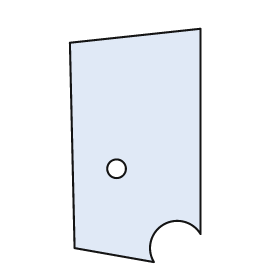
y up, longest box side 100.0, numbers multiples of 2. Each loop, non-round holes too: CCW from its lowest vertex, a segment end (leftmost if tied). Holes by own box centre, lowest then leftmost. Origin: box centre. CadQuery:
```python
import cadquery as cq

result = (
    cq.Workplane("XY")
    .moveTo(8.0, -50.0)
    .threePointArc((12.0, -34.0), (28.0, -38.0))
    .lineTo(28.0, 50.0)
    .lineTo(-28.0, 44.0)
    .lineTo(-26.0, -44.0)
    .close()
    .moveTo(-8.0, -10.0)
    .circle(4.0)
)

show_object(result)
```